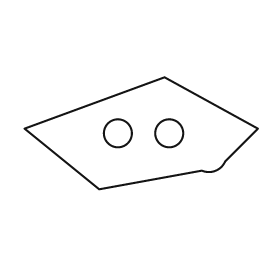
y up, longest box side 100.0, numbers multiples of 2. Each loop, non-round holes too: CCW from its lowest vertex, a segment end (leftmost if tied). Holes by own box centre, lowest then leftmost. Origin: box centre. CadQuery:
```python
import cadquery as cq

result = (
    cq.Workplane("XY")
    .moveTo(-18.0, -24.0)
    .lineTo(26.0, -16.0)
    .threePointArc((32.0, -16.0), (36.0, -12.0))
    .lineTo(50.0, 2.0)
    .lineTo(10.0, 24.0)
    .lineTo(-50.0, 2.0)
    .close()
    .moveTo(-10.0, 0.0)
    .circle(6.0)
    .moveTo(12.0, 0.0)
    .circle(6.0)
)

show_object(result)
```